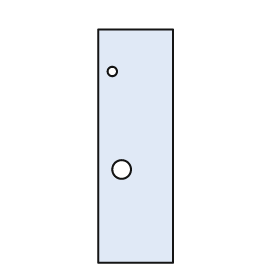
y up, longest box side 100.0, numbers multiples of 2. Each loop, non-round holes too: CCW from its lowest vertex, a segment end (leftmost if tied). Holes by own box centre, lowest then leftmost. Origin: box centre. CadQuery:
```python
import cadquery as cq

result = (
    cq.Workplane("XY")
    .moveTo(-16.0, -50.0)
    .lineTo(16.0, -50.0)
    .lineTo(16.0, 50.0)
    .lineTo(-16.0, 50.0)
    .close()
    .moveTo(-6.0, -10.0)
    .circle(4.0)
    .moveTo(-10.0, 32.0)
    .circle(2.0)
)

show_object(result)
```